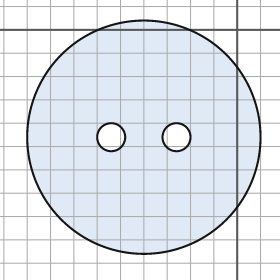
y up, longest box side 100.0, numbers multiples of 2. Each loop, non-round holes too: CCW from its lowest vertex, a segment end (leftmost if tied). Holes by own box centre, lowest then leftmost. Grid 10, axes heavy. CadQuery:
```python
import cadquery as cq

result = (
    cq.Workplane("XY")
    .moveTo(-40.0, -46.0)
    .circle(50.0)
    .moveTo(-54.0, -46.0)
    .circle(6.0)
    .moveTo(-26.0, -46.0)
    .circle(6.0)
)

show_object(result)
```